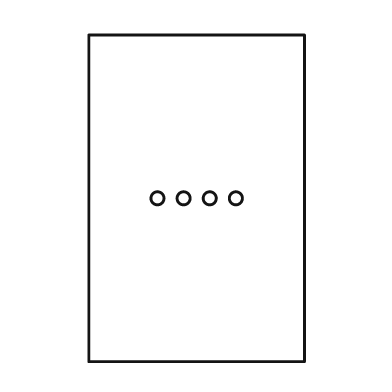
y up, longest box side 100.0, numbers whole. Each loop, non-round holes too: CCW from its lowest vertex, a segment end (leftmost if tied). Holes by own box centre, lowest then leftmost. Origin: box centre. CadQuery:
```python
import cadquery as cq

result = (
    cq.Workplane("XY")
    .moveTo(-33.0, -50.0)
    .lineTo(33.0, -50.0)
    .lineTo(33.0, 50.0)
    .lineTo(-33.0, 50.0)
    .close()
    .moveTo(-12.0, 0.0)
    .circle(2.0)
    .moveTo(-4.0, 0.0)
    .circle(2.0)
    .moveTo(4.0, 0.0)
    .circle(2.0)
    .moveTo(12.0, 0.0)
    .circle(2.0)
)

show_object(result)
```